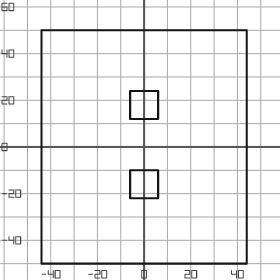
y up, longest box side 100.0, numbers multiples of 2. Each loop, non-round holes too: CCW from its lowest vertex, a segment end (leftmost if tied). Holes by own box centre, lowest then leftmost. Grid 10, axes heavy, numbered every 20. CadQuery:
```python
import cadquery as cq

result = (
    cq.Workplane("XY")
    .moveTo(-44.0, -50.0)
    .lineTo(44.0, -50.0)
    .lineTo(44.0, 50.0)
    .lineTo(-44.0, 50.0)
    .close()
    .moveTo(-6.0, -22.0)
    .lineTo(6.0, -22.0)
    .lineTo(6.0, -10.0)
    .lineTo(-6.0, -10.0)
    .close()
    .moveTo(-6.0, 12.0)
    .lineTo(6.0, 12.0)
    .lineTo(6.0, 24.0)
    .lineTo(-6.0, 24.0)
    .close()
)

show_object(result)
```